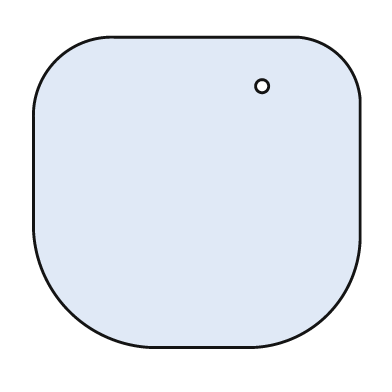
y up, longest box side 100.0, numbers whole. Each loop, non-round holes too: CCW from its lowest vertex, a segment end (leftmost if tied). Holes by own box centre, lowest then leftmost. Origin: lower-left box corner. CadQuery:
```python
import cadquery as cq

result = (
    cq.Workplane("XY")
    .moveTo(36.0, 0.0)
    .lineTo(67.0, 0.0)
    .threePointArc((90.0, 10.0), (100.0, 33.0))
    .lineTo(100.0, 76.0)
    .threePointArc((94.0, 89.0), (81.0, 95.0))
    .lineTo(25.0, 95.0)
    .threePointArc((7.0, 88.0), (0.0, 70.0))
    .lineTo(0.0, 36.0)
    .threePointArc((11.0, 11.0), (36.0, 0.0))
    .close()
    .moveTo(70.0, 80.0)
    .circle(2.0)
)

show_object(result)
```